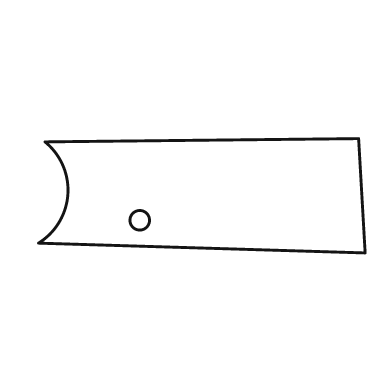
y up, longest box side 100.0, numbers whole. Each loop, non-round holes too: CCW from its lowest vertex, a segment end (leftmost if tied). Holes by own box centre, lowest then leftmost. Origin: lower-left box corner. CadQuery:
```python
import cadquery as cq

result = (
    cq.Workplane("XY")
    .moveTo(100.0, 0.0)
    .lineTo(98.0, 35.0)
    .lineTo(2.0, 34.0)
    .threePointArc((9.0, 18.0), (0.0, 3.0))
    .close()
    .moveTo(31.0, 10.0)
    .circle(3.0)
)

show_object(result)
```